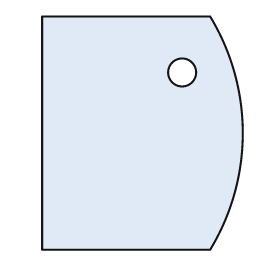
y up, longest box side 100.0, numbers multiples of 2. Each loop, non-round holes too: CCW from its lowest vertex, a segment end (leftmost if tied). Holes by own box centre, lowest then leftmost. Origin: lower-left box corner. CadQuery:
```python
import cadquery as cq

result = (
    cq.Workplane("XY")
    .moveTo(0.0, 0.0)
    .lineTo(72.0, 0.0)
    .threePointArc((86.0, 50.0), (72.0, 100.0))
    .lineTo(0.0, 100.0)
    .close()
    .moveTo(60.0, 76.0)
    .circle(6.0)
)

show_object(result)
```